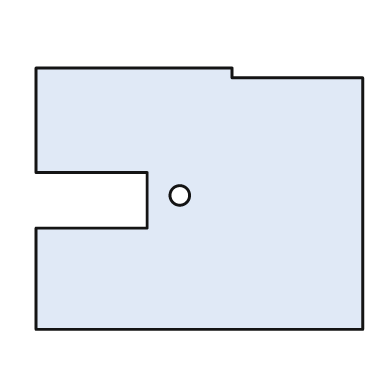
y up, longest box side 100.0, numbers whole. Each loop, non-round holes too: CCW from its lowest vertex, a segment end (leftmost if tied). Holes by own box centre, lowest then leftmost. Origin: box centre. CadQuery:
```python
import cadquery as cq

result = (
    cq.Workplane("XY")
    .moveTo(-50.0, -40.0)
    .lineTo(50.0, -40.0)
    .lineTo(50.0, 37.0)
    .lineTo(10.0, 37.0)
    .lineTo(10.0, 40.0)
    .lineTo(-50.0, 40.0)
    .lineTo(-50.0, 8.0)
    .lineTo(-16.0, 8.0)
    .lineTo(-16.0, -9.0)
    .lineTo(-50.0, -9.0)
    .close()
    .moveTo(-6.0, 1.0)
    .circle(3.0)
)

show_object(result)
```